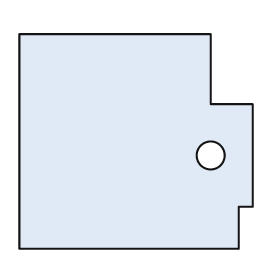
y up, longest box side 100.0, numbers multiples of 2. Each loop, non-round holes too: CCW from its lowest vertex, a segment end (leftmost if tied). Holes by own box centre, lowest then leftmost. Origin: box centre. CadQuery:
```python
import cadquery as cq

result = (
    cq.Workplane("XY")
    .moveTo(-50.0, -46.0)
    .lineTo(44.0, -46.0)
    .lineTo(44.0, -28.0)
    .lineTo(50.0, -28.0)
    .lineTo(50.0, 16.0)
    .lineTo(32.0, 16.0)
    .lineTo(32.0, 46.0)
    .lineTo(-50.0, 46.0)
    .close()
    .moveTo(32.0, -6.0)
    .circle(6.0)
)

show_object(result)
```